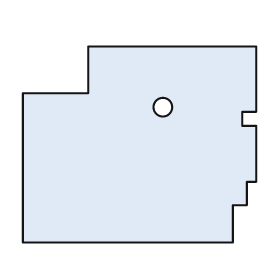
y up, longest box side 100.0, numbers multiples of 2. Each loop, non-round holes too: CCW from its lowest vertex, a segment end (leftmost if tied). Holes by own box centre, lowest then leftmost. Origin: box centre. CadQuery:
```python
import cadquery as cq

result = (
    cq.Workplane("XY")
    .moveTo(-50.0, -42.0)
    .lineTo(40.0, -42.0)
    .lineTo(40.0, -26.0)
    .lineTo(46.0, -26.0)
    .lineTo(46.0, -16.0)
    .lineTo(50.0, -16.0)
    .lineTo(50.0, 8.0)
    .lineTo(44.0, 8.0)
    .lineTo(44.0, 14.0)
    .lineTo(50.0, 14.0)
    .lineTo(50.0, 42.0)
    .lineTo(-22.0, 42.0)
    .lineTo(-22.0, 22.0)
    .lineTo(-50.0, 22.0)
    .close()
    .moveTo(10.0, 16.0)
    .circle(4.0)
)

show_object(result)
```